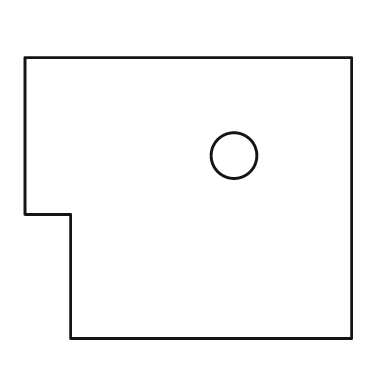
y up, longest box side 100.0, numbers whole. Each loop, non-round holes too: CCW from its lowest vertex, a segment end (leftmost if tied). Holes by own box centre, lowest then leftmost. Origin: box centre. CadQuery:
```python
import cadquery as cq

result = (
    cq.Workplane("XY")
    .moveTo(-36.0, -43.0)
    .lineTo(50.0, -43.0)
    .lineTo(50.0, 43.0)
    .lineTo(-50.0, 43.0)
    .lineTo(-50.0, -5.0)
    .lineTo(-36.0, -5.0)
    .close()
    .moveTo(14.0, 13.0)
    .circle(7.0)
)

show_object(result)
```